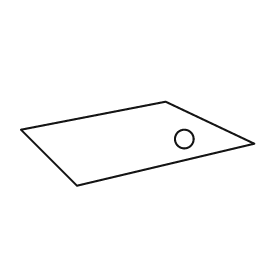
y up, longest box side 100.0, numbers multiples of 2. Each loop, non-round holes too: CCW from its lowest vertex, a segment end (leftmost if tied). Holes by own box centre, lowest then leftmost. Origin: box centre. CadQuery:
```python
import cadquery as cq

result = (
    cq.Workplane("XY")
    .moveTo(-26.0, -18.0)
    .lineTo(50.0, 0.0)
    .lineTo(12.0, 18.0)
    .lineTo(-50.0, 6.0)
    .close()
    .moveTo(20.0, 2.0)
    .circle(4.0)
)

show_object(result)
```